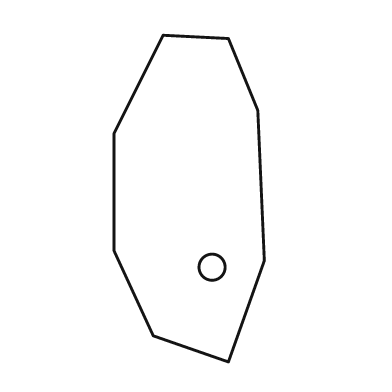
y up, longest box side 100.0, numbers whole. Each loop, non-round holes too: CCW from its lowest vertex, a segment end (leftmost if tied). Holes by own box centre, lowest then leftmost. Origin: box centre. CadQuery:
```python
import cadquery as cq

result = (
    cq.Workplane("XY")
    .moveTo(12.0, -50.0)
    .lineTo(23.0, -19.0)
    .lineTo(21.0, 27.0)
    .lineTo(12.0, 49.0)
    .lineTo(-8.0, 50.0)
    .lineTo(-23.0, 20.0)
    .lineTo(-23.0, -16.0)
    .lineTo(-11.0, -42.0)
    .close()
    .moveTo(7.0, -21.0)
    .circle(4.0)
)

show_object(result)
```